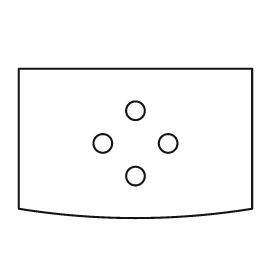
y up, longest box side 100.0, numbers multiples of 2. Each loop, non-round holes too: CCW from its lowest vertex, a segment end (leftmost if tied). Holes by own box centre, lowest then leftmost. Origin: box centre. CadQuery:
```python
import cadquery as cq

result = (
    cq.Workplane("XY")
    .moveTo(-50.0, -28.0)
    .threePointArc((0.0, -32.0), (50.0, -28.0))
    .lineTo(50.0, 32.0)
    .lineTo(-50.0, 32.0)
    .close()
    .moveTo(0.0, -14.0)
    .circle(4.0)
    .moveTo(-14.0, 0.0)
    .circle(4.0)
    .moveTo(14.0, 0.0)
    .circle(4.0)
    .moveTo(0.0, 14.0)
    .circle(4.0)
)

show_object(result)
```